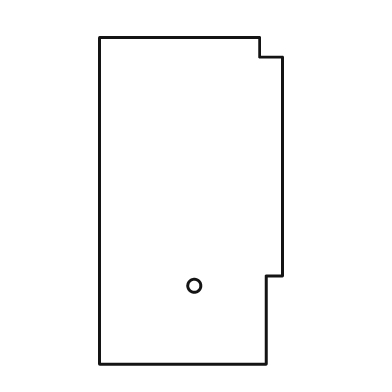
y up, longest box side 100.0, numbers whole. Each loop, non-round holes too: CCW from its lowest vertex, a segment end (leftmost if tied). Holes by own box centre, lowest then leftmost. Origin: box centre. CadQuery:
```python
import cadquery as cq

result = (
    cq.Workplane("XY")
    .moveTo(-28.0, -50.0)
    .lineTo(23.0, -50.0)
    .lineTo(23.0, -23.0)
    .lineTo(28.0, -23.0)
    .lineTo(28.0, 44.0)
    .lineTo(21.0, 44.0)
    .lineTo(21.0, 50.0)
    .lineTo(-28.0, 50.0)
    .close()
    .moveTo(1.0, -26.0)
    .circle(2.0)
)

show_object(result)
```